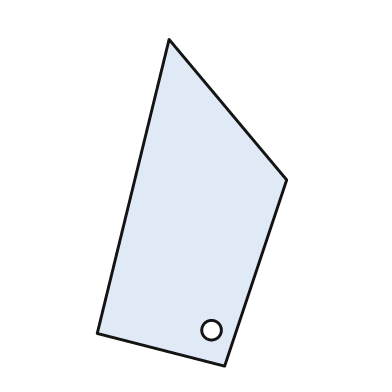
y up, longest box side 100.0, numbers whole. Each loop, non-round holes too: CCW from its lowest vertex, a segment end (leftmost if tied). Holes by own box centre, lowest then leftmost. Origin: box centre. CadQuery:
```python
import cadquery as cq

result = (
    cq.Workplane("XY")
    .moveTo(10.0, -50.0)
    .lineTo(29.0, 7.0)
    .lineTo(-7.0, 50.0)
    .lineTo(-29.0, -40.0)
    .close()
    .moveTo(6.0, -39.0)
    .circle(3.0)
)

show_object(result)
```